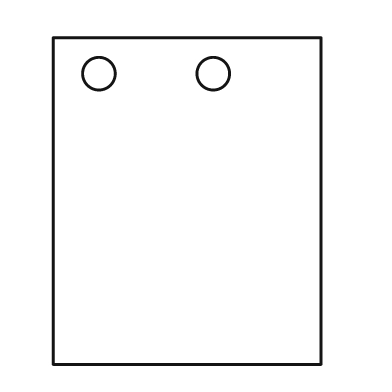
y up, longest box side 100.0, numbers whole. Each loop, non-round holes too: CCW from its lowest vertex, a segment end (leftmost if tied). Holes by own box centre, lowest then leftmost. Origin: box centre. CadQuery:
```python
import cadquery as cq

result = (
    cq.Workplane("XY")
    .moveTo(-41.0, -50.0)
    .lineTo(41.0, -50.0)
    .lineTo(41.0, 50.0)
    .lineTo(-41.0, 50.0)
    .close()
    .moveTo(-27.0, 39.0)
    .circle(5.0)
    .moveTo(8.0, 39.0)
    .circle(5.0)
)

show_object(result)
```